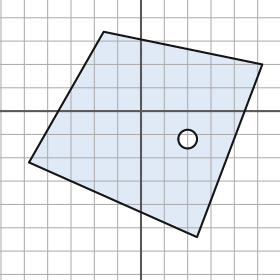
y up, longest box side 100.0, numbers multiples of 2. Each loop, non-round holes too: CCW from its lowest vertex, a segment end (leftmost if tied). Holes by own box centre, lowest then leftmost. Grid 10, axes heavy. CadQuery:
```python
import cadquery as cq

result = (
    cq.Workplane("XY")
    .moveTo(24.0, -54.0)
    .lineTo(52.0, 20.0)
    .lineTo(-16.0, 34.0)
    .lineTo(-48.0, -22.0)
    .close()
    .moveTo(20.0, -12.0)
    .circle(4.0)
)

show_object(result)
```